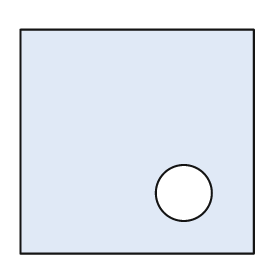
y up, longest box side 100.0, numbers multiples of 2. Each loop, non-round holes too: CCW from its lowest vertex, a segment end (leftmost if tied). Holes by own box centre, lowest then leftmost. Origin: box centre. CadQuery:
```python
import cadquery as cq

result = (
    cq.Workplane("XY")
    .moveTo(-50.0, -48.0)
    .lineTo(50.0, -48.0)
    .lineTo(50.0, 48.0)
    .lineTo(-50.0, 48.0)
    .close()
    .moveTo(20.0, -22.0)
    .circle(12.0)
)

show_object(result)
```